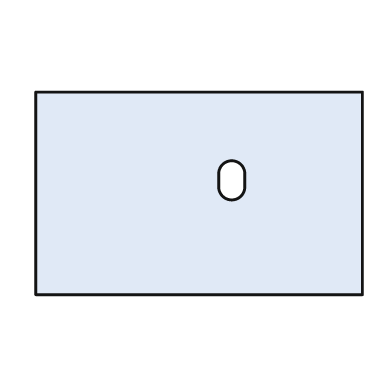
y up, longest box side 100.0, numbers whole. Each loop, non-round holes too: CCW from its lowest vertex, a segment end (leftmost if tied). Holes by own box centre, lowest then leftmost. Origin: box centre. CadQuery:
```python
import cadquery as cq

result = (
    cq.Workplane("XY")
    .moveTo(-50.0, -31.0)
    .lineTo(50.0, -31.0)
    .lineTo(50.0, 31.0)
    .lineTo(-50.0, 31.0)
    .close()
    .moveTo(6.0, 2.0)
    .threePointArc((10.0, -2.0), (14.0, 2.0))
    .lineTo(14.0, 6.0)
    .threePointArc((10.0, 10.0), (6.0, 6.0))
    .close()
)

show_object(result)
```